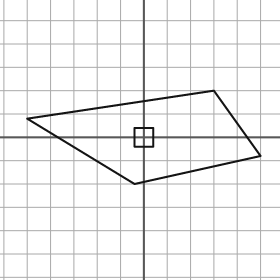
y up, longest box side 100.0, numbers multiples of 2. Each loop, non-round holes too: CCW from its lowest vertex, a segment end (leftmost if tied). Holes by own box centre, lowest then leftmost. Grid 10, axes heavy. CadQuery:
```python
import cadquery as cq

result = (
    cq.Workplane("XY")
    .moveTo(-4.0, -20.0)
    .lineTo(50.0, -8.0)
    .lineTo(30.0, 20.0)
    .lineTo(-50.0, 8.0)
    .close()
    .moveTo(-4.0, -4.0)
    .lineTo(4.0, -4.0)
    .lineTo(4.0, 4.0)
    .lineTo(-4.0, 4.0)
    .close()
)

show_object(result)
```